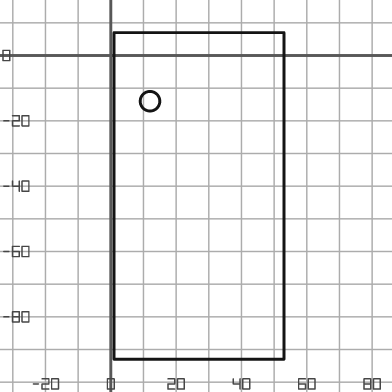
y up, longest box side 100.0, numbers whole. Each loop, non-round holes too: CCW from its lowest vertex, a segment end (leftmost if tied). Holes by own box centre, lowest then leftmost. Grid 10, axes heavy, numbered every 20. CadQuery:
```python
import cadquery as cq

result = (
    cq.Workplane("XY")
    .moveTo(1.0, -93.0)
    .lineTo(53.0, -93.0)
    .lineTo(53.0, 7.0)
    .lineTo(1.0, 7.0)
    .close()
    .moveTo(12.0, -14.0)
    .circle(3.0)
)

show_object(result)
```